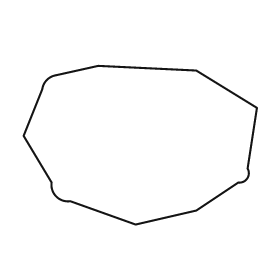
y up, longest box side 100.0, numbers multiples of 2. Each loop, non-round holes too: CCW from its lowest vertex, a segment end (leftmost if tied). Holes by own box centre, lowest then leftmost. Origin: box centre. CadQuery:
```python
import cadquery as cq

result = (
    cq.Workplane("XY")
    .moveTo(-2.0, -34.0)
    .lineTo(24.0, -28.0)
    .lineTo(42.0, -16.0)
    .threePointArc((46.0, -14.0), (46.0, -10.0))
    .lineTo(50.0, 16.0)
    .lineTo(24.0, 32.0)
    .lineTo(-18.0, 34.0)
    .lineTo(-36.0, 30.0)
    .threePointArc((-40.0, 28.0), (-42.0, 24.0))
    .lineTo(-50.0, 4.0)
    .lineTo(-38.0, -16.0)
    .threePointArc((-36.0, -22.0), (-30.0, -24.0))
    .close()
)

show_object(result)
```